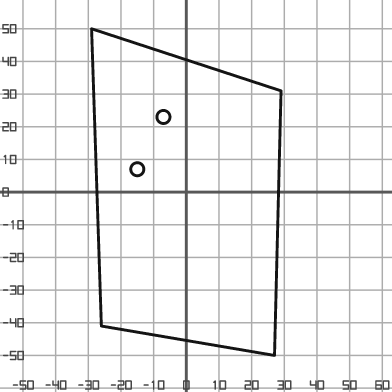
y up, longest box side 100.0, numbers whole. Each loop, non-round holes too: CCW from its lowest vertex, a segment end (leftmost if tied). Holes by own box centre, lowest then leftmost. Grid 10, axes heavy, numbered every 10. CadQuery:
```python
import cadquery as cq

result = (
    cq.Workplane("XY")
    .moveTo(27.0, -50.0)
    .lineTo(29.0, 31.0)
    .lineTo(-29.0, 50.0)
    .lineTo(-26.0, -41.0)
    .close()
    .moveTo(-15.0, 7.0)
    .circle(2.0)
    .moveTo(-7.0, 23.0)
    .circle(2.0)
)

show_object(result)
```